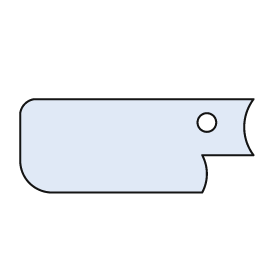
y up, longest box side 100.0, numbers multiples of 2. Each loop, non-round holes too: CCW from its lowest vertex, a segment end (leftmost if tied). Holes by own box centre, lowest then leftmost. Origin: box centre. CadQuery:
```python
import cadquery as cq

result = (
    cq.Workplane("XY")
    .moveTo(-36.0, -20.0)
    .lineTo(28.0, -20.0)
    .threePointArc((30.0, -12.0), (28.0, -4.0))
    .lineTo(50.0, -4.0)
    .threePointArc((46.0, 8.0), (50.0, 20.0))
    .lineTo(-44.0, 20.0)
    .threePointArc((-48.0, 18.0), (-50.0, 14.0))
    .lineTo(-50.0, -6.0)
    .threePointArc((-46.0, -16.0), (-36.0, -20.0))
    .close()
    .moveTo(30.0, 10.0)
    .circle(4.0)
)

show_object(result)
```